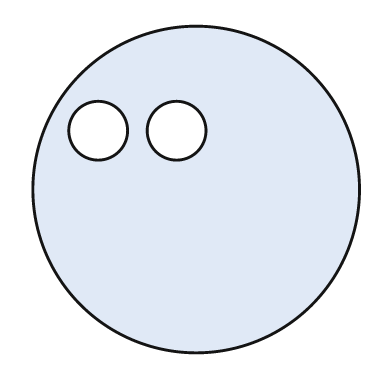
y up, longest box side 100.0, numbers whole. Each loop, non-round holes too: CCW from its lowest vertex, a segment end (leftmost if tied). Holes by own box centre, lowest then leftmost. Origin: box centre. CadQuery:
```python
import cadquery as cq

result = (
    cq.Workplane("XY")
    .moveTo(0.0, 0.0)
    .circle(50.0)
    .moveTo(-30.0, 18.0)
    .circle(9.0)
    .moveTo(-6.0, 18.0)
    .circle(9.0)
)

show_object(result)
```